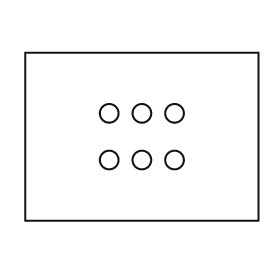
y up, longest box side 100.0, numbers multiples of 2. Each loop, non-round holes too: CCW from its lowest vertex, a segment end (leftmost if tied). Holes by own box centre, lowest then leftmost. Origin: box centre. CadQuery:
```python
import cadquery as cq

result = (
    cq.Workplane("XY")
    .moveTo(-50.0, -36.0)
    .lineTo(50.0, -36.0)
    .lineTo(50.0, 36.0)
    .lineTo(-50.0, 36.0)
    .close()
    .moveTo(-14.0, -10.0)
    .circle(4.0)
    .moveTo(0.0, -10.0)
    .circle(4.0)
    .moveTo(14.0, -10.0)
    .circle(4.0)
    .moveTo(-14.0, 10.0)
    .circle(4.0)
    .moveTo(0.0, 10.0)
    .circle(4.0)
    .moveTo(14.0, 10.0)
    .circle(4.0)
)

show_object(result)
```